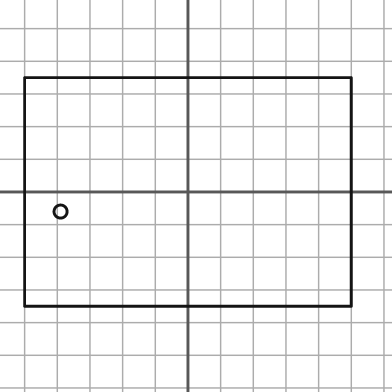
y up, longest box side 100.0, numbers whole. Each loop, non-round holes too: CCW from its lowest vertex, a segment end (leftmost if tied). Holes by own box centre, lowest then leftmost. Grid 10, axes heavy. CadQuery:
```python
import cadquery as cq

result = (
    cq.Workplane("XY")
    .moveTo(-50.0, -35.0)
    .lineTo(50.0, -35.0)
    .lineTo(50.0, 35.0)
    .lineTo(-50.0, 35.0)
    .close()
    .moveTo(-39.0, -6.0)
    .circle(2.0)
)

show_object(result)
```